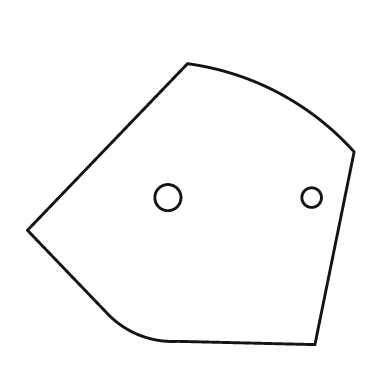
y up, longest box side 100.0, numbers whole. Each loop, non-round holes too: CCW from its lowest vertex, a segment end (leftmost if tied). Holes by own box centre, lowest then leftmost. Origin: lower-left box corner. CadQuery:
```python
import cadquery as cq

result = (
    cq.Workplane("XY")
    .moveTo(88.0, 0.0)
    .lineTo(100.0, 59.0)
    .threePointArc((77.0, 77.0), (49.0, 86.0))
    .lineTo(0.0, 35.0)
    .lineTo(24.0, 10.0)
    .threePointArc((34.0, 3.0), (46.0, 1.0))
    .close()
    .moveTo(43.0, 45.0)
    .circle(4.0)
    .moveTo(87.0, 45.0)
    .circle(3.0)
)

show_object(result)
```